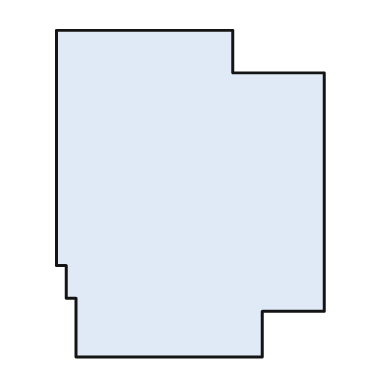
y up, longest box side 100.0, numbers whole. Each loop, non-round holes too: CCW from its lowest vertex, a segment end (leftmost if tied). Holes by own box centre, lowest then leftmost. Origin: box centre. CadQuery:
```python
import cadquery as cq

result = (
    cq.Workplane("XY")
    .moveTo(-35.0, -50.0)
    .lineTo(22.0, -50.0)
    .lineTo(22.0, -36.0)
    .lineTo(41.0, -36.0)
    .lineTo(41.0, 37.0)
    .lineTo(13.0, 37.0)
    .lineTo(13.0, 50.0)
    .lineTo(-41.0, 50.0)
    .lineTo(-41.0, -22.0)
    .lineTo(-38.0, -22.0)
    .lineTo(-38.0, -32.0)
    .lineTo(-35.0, -32.0)
    .close()
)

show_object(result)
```